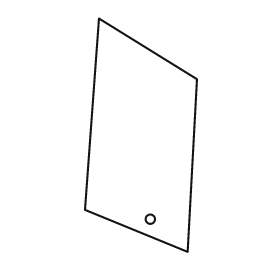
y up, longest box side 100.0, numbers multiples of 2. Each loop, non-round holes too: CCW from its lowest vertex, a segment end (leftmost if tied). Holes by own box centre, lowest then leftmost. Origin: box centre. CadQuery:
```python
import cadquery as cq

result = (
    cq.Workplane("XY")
    .moveTo(20.0, -50.0)
    .lineTo(24.0, 24.0)
    .lineTo(-18.0, 50.0)
    .lineTo(-24.0, -32.0)
    .close()
    .moveTo(4.0, -36.0)
    .circle(2.0)
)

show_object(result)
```